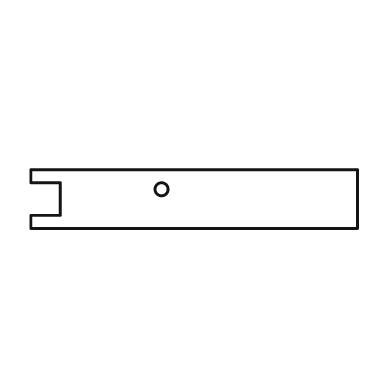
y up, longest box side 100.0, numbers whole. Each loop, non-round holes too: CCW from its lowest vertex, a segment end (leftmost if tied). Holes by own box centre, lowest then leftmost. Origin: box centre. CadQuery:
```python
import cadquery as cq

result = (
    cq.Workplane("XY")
    .moveTo(-50.0, -9.0)
    .lineTo(50.0, -9.0)
    .lineTo(50.0, 9.0)
    .lineTo(-50.0, 9.0)
    .lineTo(-50.0, 5.0)
    .lineTo(-41.0, 5.0)
    .lineTo(-41.0, -5.0)
    .lineTo(-50.0, -5.0)
    .close()
    .moveTo(-10.0, 3.0)
    .circle(2.0)
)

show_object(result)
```